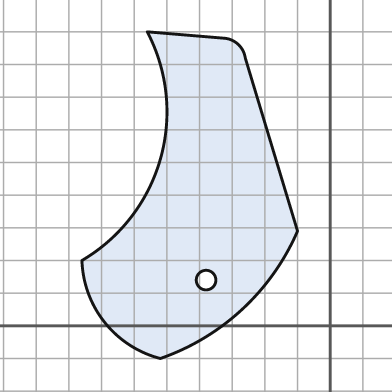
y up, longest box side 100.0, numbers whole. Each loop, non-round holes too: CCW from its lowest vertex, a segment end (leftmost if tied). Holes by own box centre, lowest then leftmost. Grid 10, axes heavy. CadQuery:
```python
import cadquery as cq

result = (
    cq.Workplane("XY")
    .moveTo(-52.0, -10.0)
    .threePointArc((-27.0, 5.0), (-10.0, 29.0))
    .lineTo(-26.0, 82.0)
    .threePointArc((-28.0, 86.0), (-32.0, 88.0))
    .lineTo(-56.0, 90.0)
    .threePointArc((-52.0, 51.0), (-76.0, 20.0))
    .threePointArc((-69.0, 1.0), (-52.0, -10.0))
    .close()
    .moveTo(-38.0, 14.0)
    .circle(3.0)
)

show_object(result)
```